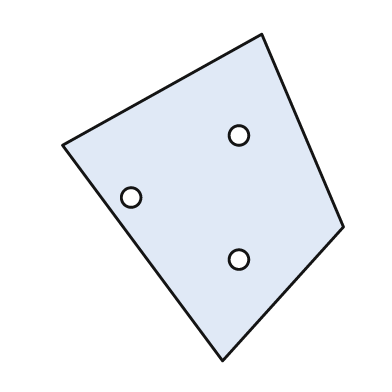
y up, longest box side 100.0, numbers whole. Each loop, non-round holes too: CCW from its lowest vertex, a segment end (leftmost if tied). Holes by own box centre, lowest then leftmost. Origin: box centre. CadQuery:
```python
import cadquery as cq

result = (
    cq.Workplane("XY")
    .moveTo(6.0, -50.0)
    .lineTo(43.0, -9.0)
    .lineTo(18.0, 50.0)
    .lineTo(-43.0, 16.0)
    .close()
    .moveTo(11.0, -19.0)
    .circle(3.0)
    .moveTo(-22.0, 0.0)
    .circle(3.0)
    .moveTo(11.0, 19.0)
    .circle(3.0)
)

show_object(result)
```